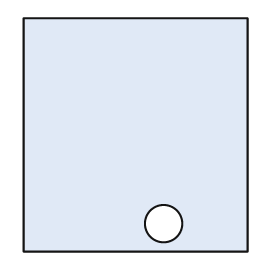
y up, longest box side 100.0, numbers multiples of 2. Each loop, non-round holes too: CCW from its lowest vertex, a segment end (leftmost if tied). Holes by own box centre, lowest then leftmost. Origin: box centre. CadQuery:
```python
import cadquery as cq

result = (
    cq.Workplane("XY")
    .moveTo(-48.0, -50.0)
    .lineTo(48.0, -50.0)
    .lineTo(48.0, 50.0)
    .lineTo(-48.0, 50.0)
    .close()
    .moveTo(12.0, -38.0)
    .circle(8.0)
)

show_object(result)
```